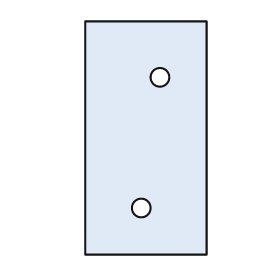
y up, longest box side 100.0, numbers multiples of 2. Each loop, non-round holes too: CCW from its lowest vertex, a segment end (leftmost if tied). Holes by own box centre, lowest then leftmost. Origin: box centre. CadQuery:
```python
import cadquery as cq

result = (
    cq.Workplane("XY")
    .moveTo(-26.0, -50.0)
    .lineTo(26.0, -50.0)
    .lineTo(26.0, 50.0)
    .lineTo(-26.0, 50.0)
    .close()
    .moveTo(-2.0, -30.0)
    .circle(4.0)
    .moveTo(6.0, 26.0)
    .circle(4.0)
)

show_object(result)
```